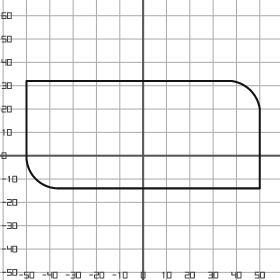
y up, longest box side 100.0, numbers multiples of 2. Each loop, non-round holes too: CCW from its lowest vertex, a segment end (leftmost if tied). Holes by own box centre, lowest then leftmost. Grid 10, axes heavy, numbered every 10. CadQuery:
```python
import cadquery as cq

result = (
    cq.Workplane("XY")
    .moveTo(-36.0, -14.0)
    .lineTo(50.0, -14.0)
    .lineTo(50.0, 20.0)
    .threePointArc((46.0, 28.0), (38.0, 32.0))
    .lineTo(-50.0, 32.0)
    .lineTo(-50.0, 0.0)
    .threePointArc((-46.0, -10.0), (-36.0, -14.0))
    .close()
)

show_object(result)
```